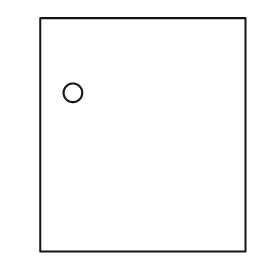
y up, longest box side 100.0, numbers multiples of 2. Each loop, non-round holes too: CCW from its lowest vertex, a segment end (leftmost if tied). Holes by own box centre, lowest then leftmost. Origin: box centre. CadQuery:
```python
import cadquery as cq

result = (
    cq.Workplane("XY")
    .moveTo(-44.0, -50.0)
    .lineTo(44.0, -50.0)
    .lineTo(44.0, 50.0)
    .lineTo(-44.0, 50.0)
    .close()
    .moveTo(-30.0, 18.0)
    .circle(4.0)
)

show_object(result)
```